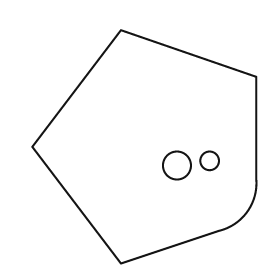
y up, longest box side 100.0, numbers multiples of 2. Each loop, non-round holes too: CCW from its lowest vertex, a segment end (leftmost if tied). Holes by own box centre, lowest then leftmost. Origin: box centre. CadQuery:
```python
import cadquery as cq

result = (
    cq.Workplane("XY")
    .moveTo(-10.0, -50.0)
    .lineTo(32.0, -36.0)
    .threePointArc((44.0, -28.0), (48.0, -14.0))
    .lineTo(48.0, 30.0)
    .lineTo(-10.0, 50.0)
    .lineTo(-48.0, 0.0)
    .close()
    .moveTo(14.0, -8.0)
    .circle(6.0)
    .moveTo(28.0, -6.0)
    .circle(4.0)
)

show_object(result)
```